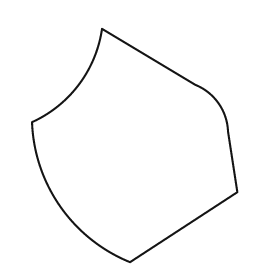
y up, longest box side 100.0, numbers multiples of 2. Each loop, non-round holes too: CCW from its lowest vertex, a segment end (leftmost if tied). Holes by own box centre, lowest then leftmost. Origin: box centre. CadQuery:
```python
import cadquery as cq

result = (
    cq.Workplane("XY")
    .moveTo(-2.0, -50.0)
    .lineTo(44.0, -20.0)
    .lineTo(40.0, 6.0)
    .threePointArc((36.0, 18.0), (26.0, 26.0))
    .lineTo(-14.0, 50.0)
    .threePointArc((-24.0, 26.0), (-44.0, 10.0))
    .threePointArc((-32.0, -26.0), (-2.0, -50.0))
    .close()
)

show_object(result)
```